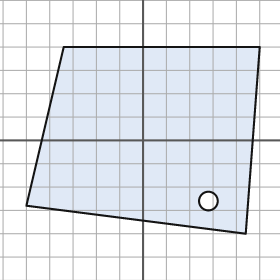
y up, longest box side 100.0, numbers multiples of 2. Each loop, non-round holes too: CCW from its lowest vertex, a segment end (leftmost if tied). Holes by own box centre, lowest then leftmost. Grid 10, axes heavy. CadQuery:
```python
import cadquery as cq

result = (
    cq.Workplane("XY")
    .moveTo(44.0, -40.0)
    .lineTo(50.0, 40.0)
    .lineTo(-34.0, 40.0)
    .lineTo(-50.0, -28.0)
    .close()
    .moveTo(28.0, -26.0)
    .circle(4.0)
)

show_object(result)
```